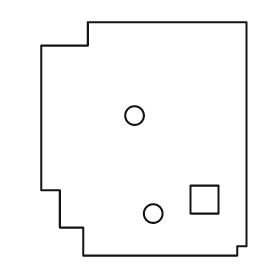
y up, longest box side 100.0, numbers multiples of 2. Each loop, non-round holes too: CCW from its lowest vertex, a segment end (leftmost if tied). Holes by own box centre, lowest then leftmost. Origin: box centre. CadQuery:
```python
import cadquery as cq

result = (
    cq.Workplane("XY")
    .moveTo(-26.0, -50.0)
    .lineTo(40.0, -50.0)
    .lineTo(40.0, -46.0)
    .lineTo(44.0, -46.0)
    .lineTo(44.0, 50.0)
    .lineTo(-24.0, 50.0)
    .lineTo(-24.0, 40.0)
    .lineTo(-44.0, 40.0)
    .lineTo(-44.0, -22.0)
    .lineTo(-36.0, -22.0)
    .lineTo(-36.0, -38.0)
    .lineTo(-26.0, -38.0)
    .close()
    .moveTo(4.0, -32.0)
    .circle(4.0)
    .moveTo(20.0, -32.0)
    .lineTo(32.0, -32.0)
    .lineTo(32.0, -20.0)
    .lineTo(20.0, -20.0)
    .close()
    .moveTo(-4.0, 10.0)
    .circle(4.0)
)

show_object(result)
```